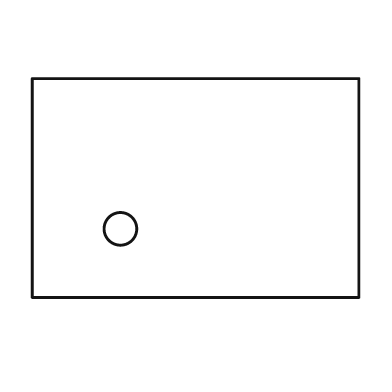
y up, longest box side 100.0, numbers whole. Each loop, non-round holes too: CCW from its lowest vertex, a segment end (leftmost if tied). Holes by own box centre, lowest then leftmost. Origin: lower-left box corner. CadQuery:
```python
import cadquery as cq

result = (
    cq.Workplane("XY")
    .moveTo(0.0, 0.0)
    .lineTo(100.0, 0.0)
    .lineTo(100.0, 67.0)
    .lineTo(0.0, 67.0)
    .close()
    .moveTo(27.0, 21.0)
    .circle(5.0)
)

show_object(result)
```